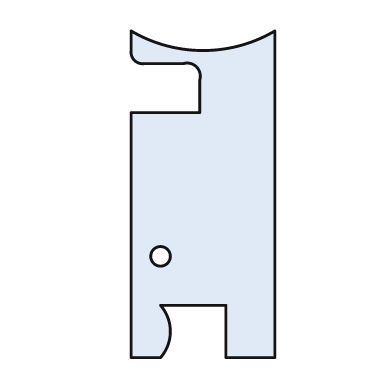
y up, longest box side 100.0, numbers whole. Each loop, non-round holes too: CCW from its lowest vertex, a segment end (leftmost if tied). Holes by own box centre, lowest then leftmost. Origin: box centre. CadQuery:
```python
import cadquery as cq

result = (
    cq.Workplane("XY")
    .moveTo(-22.0, -50.0)
    .lineTo(-13.0, -50.0)
    .threePointArc((-10.0, -42.0), (-13.0, -34.0))
    .lineTo(7.0, -34.0)
    .lineTo(7.0, -50.0)
    .lineTo(22.0, -50.0)
    .lineTo(22.0, 50.0)
    .threePointArc((0.0, 44.0), (-22.0, 50.0))
    .lineTo(-22.0, 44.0)
    .threePointArc((-21.0, 41.0), (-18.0, 40.0))
    .lineTo(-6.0, 40.0)
    .threePointArc((-2.0, 39.0), (-1.0, 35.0))
    .lineTo(-1.0, 25.0)
    .lineTo(-22.0, 25.0)
    .close()
    .moveTo(-13.0, -19.0)
    .circle(3.0)
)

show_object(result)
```